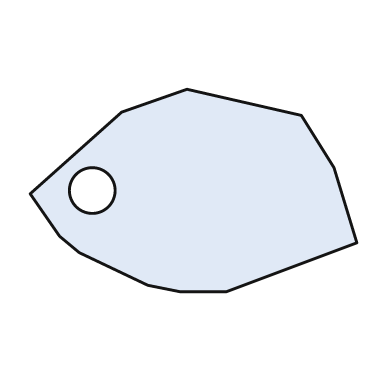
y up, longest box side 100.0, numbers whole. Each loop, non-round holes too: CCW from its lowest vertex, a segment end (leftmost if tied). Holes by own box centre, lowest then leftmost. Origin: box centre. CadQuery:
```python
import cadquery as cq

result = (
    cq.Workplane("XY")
    .moveTo(-4.0, -31.0)
    .lineTo(10.0, -31.0)
    .lineTo(50.0, -16.0)
    .lineTo(43.0, 7.0)
    .lineTo(33.0, 23.0)
    .lineTo(-2.0, 31.0)
    .lineTo(-22.0, 24.0)
    .lineTo(-50.0, -1.0)
    .lineTo(-41.0, -14.0)
    .lineTo(-35.0, -19.0)
    .lineTo(-14.0, -29.0)
    .close()
    .moveTo(-31.0, 0.0)
    .circle(7.0)
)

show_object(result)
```